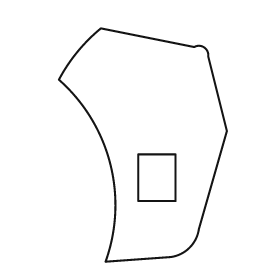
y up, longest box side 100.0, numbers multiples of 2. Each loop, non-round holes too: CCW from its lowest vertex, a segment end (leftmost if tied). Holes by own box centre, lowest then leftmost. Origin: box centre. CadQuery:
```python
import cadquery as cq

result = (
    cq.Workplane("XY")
    .moveTo(-16.0, -50.0)
    .lineTo(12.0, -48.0)
    .threePointArc((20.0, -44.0), (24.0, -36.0))
    .lineTo(36.0, 6.0)
    .lineTo(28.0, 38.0)
    .threePointArc((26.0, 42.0), (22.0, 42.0))
    .lineTo(-18.0, 50.0)
    .threePointArc((-28.0, 40.0), (-36.0, 28.0))
    .threePointArc((-14.0, -8.0), (-16.0, -50.0))
    .close()
    .moveTo(-2.0, -24.0)
    .lineTo(14.0, -24.0)
    .lineTo(14.0, -4.0)
    .lineTo(-2.0, -4.0)
    .close()
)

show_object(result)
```